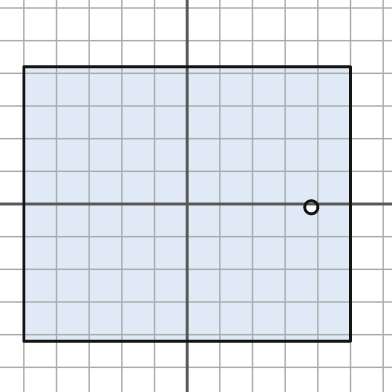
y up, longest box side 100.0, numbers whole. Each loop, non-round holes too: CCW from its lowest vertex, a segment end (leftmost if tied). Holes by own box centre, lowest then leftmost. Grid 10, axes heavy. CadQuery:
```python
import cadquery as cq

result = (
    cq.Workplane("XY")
    .moveTo(-50.0, -42.0)
    .lineTo(50.0, -42.0)
    .lineTo(50.0, 42.0)
    .lineTo(-50.0, 42.0)
    .close()
    .moveTo(38.0, -1.0)
    .circle(2.0)
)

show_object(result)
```